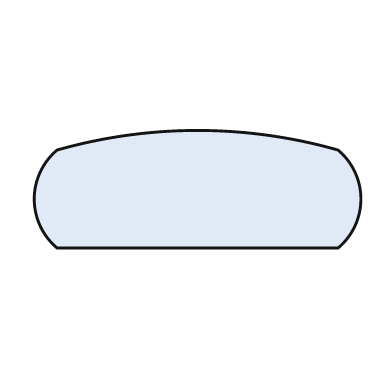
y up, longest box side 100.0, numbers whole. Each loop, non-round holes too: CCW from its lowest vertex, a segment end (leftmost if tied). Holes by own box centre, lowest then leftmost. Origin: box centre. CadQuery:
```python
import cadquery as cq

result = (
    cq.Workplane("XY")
    .moveTo(-43.0, -18.0)
    .lineTo(43.0, -18.0)
    .threePointArc((50.0, -3.0), (43.0, 12.0))
    .threePointArc((0.0, 18.0), (-43.0, 12.0))
    .threePointArc((-50.0, -3.0), (-43.0, -18.0))
    .close()
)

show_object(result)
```